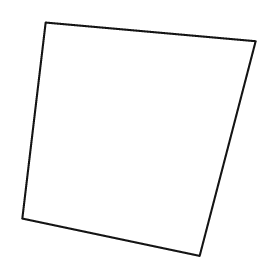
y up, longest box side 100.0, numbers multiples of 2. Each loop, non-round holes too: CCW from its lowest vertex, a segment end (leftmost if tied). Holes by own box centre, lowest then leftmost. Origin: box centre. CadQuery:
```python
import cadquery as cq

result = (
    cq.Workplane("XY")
    .moveTo(26.0, -50.0)
    .lineTo(50.0, 42.0)
    .lineTo(-40.0, 50.0)
    .lineTo(-50.0, -34.0)
    .close()
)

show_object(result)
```